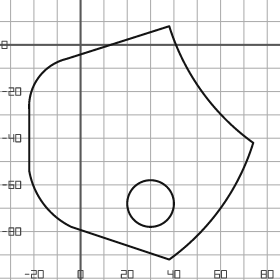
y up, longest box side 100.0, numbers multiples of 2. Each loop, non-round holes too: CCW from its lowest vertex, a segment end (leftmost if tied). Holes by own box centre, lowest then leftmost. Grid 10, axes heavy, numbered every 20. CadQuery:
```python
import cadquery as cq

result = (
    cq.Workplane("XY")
    .moveTo(38.0, -92.0)
    .threePointArc((60.0, -70.0), (74.0, -42.0))
    .threePointArc((52.0, -20.0), (38.0, 8.0))
    .lineTo(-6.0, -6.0)
    .threePointArc((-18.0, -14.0), (-22.0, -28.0))
    .lineTo(-22.0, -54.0)
    .threePointArc((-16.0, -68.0), (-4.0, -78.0))
    .close()
    .moveTo(30.0, -68.0)
    .circle(10.0)
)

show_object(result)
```